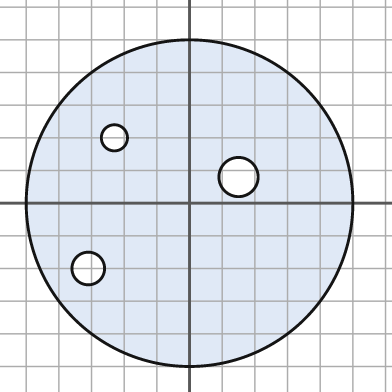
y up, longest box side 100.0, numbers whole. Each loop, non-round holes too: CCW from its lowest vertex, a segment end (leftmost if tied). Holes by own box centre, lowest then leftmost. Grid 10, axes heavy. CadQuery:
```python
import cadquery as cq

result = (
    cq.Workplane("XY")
    .moveTo(0.0, 0.0)
    .circle(50.0)
    .moveTo(-31.0, -20.0)
    .circle(5.0)
    .moveTo(15.0, 8.0)
    .circle(6.0)
    .moveTo(-23.0, 20.0)
    .circle(4.0)
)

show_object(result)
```